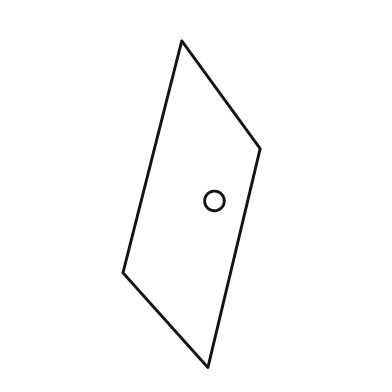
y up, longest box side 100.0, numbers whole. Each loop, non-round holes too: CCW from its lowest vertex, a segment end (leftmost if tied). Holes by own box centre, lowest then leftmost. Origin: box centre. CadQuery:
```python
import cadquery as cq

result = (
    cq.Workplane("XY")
    .moveTo(5.0, -50.0)
    .lineTo(21.0, 17.0)
    .lineTo(-3.0, 50.0)
    .lineTo(-21.0, -21.0)
    .close()
    .moveTo(7.0, 1.0)
    .circle(3.0)
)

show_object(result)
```